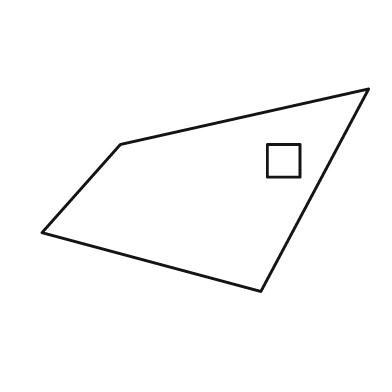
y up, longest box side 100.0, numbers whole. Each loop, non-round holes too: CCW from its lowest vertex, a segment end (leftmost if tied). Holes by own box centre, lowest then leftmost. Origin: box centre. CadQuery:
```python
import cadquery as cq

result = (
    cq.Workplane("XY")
    .moveTo(17.0, -31.0)
    .lineTo(50.0, 31.0)
    .lineTo(-26.0, 14.0)
    .lineTo(-50.0, -13.0)
    .close()
    .moveTo(19.0, 4.0)
    .lineTo(29.0, 4.0)
    .lineTo(29.0, 14.0)
    .lineTo(19.0, 14.0)
    .close()
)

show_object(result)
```